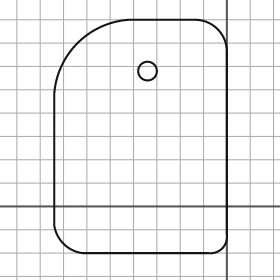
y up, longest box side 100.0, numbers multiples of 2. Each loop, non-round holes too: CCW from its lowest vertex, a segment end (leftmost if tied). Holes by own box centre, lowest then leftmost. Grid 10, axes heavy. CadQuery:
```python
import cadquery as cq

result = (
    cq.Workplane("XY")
    .moveTo(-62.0, -20.0)
    .lineTo(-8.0, -20.0)
    .threePointArc((-2.0, -18.0), (0.0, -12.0))
    .lineTo(0.0, 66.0)
    .threePointArc((-4.0, 76.0), (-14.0, 80.0))
    .lineTo(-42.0, 80.0)
    .threePointArc((-64.0, 70.0), (-74.0, 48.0))
    .lineTo(-74.0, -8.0)
    .threePointArc((-70.0, -16.0), (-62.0, -20.0))
    .close()
    .moveTo(-34.0, 58.0)
    .circle(4.0)
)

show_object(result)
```